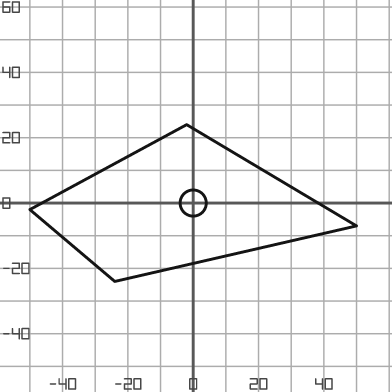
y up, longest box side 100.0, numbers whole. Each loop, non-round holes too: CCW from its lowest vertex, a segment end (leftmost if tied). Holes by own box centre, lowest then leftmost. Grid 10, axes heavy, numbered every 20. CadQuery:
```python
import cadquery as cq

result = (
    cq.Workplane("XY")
    .moveTo(-24.0, -24.0)
    .lineTo(50.0, -7.0)
    .lineTo(-2.0, 24.0)
    .lineTo(-50.0, -2.0)
    .close()
    .moveTo(0.0, 0.0)
    .circle(4.0)
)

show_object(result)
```